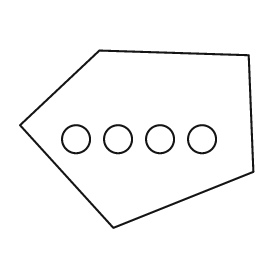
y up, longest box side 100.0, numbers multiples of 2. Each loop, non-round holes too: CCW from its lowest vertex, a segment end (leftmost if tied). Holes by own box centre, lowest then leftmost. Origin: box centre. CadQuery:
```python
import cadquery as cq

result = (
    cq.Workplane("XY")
    .moveTo(-10.0, -38.0)
    .lineTo(50.0, -14.0)
    .lineTo(48.0, 36.0)
    .lineTo(-16.0, 38.0)
    .lineTo(-50.0, 6.0)
    .close()
    .moveTo(-26.0, 0.0)
    .circle(6.0)
    .moveTo(-8.0, 0.0)
    .circle(6.0)
    .moveTo(10.0, 0.0)
    .circle(6.0)
    .moveTo(28.0, 0.0)
    .circle(6.0)
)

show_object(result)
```